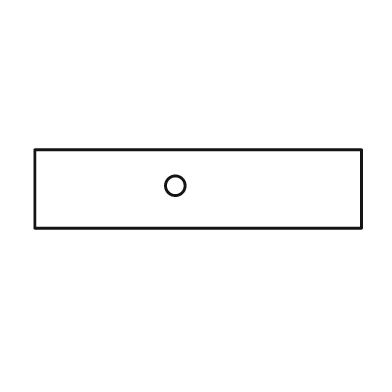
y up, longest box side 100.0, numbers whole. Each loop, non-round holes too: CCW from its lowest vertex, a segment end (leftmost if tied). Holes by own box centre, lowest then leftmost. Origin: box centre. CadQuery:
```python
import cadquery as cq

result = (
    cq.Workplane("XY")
    .moveTo(-50.0, -12.0)
    .lineTo(50.0, -12.0)
    .lineTo(50.0, 12.0)
    .lineTo(-50.0, 12.0)
    .close()
    .moveTo(-7.0, 1.0)
    .circle(3.0)
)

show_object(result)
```